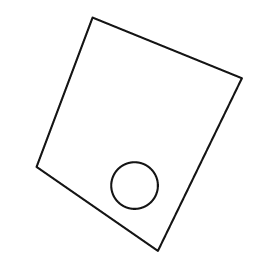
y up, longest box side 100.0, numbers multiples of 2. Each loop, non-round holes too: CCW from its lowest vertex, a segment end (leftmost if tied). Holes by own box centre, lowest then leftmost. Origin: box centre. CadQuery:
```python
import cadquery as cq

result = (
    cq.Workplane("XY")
    .moveTo(8.0, -50.0)
    .lineTo(44.0, 24.0)
    .lineTo(-20.0, 50.0)
    .lineTo(-44.0, -14.0)
    .close()
    .moveTo(-2.0, -22.0)
    .circle(10.0)
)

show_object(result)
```